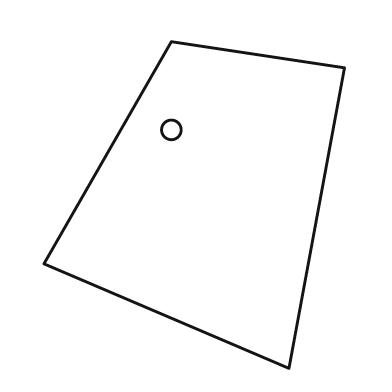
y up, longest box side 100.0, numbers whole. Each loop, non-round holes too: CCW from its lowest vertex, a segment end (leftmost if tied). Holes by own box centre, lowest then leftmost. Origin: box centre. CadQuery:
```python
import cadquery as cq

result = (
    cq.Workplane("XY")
    .moveTo(29.0, -50.0)
    .lineTo(46.0, 42.0)
    .lineTo(-7.0, 50.0)
    .lineTo(-46.0, -18.0)
    .close()
    .moveTo(-7.0, 23.0)
    .circle(3.0)
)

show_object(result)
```